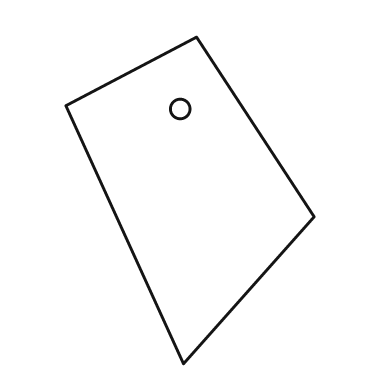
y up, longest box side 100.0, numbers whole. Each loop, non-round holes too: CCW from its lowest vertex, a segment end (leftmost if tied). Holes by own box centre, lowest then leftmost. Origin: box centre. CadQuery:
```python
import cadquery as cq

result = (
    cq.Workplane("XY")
    .moveTo(-2.0, -50.0)
    .lineTo(38.0, -5.0)
    .lineTo(2.0, 50.0)
    .lineTo(-38.0, 29.0)
    .close()
    .moveTo(-3.0, 28.0)
    .circle(3.0)
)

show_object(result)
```